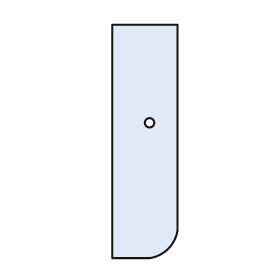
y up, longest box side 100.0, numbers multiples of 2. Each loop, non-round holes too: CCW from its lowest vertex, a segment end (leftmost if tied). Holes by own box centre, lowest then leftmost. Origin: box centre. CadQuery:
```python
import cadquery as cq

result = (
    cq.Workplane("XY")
    .moveTo(-14.0, -50.0)
    .lineTo(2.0, -50.0)
    .threePointArc((10.0, -46.0), (14.0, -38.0))
    .lineTo(14.0, 50.0)
    .lineTo(-14.0, 50.0)
    .close()
    .moveTo(2.0, 8.0)
    .circle(2.0)
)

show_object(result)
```